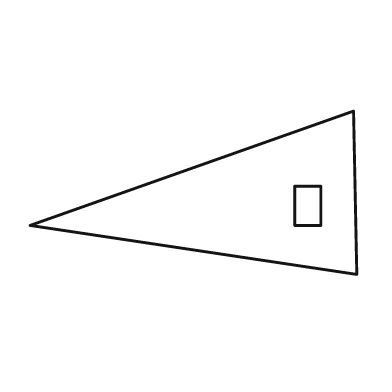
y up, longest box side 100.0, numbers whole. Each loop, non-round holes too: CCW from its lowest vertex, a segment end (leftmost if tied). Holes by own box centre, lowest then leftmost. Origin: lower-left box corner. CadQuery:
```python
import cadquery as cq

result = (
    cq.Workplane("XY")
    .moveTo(100.0, 0.0)
    .lineTo(99.0, 50.0)
    .lineTo(0.0, 15.0)
    .close()
    .moveTo(81.0, 15.0)
    .lineTo(89.0, 15.0)
    .lineTo(89.0, 27.0)
    .lineTo(81.0, 27.0)
    .close()
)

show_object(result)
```